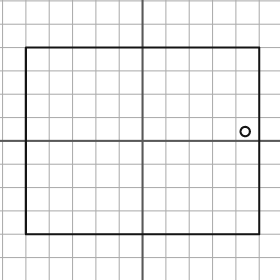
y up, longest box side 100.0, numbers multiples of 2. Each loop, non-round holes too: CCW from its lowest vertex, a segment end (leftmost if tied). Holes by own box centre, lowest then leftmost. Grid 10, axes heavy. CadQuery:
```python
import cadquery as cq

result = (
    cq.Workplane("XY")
    .moveTo(-50.0, -40.0)
    .lineTo(50.0, -40.0)
    .lineTo(50.0, 40.0)
    .lineTo(-50.0, 40.0)
    .close()
    .moveTo(44.0, 4.0)
    .circle(2.0)
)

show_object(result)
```